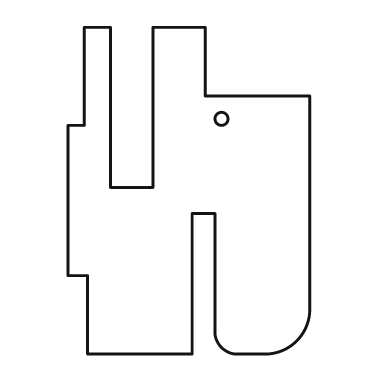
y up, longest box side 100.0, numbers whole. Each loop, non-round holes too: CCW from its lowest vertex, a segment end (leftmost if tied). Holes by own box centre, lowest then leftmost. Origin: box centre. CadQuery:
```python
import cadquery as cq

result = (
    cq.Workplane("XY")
    .moveTo(-31.0, -50.0)
    .lineTo(1.0, -50.0)
    .lineTo(1.0, -7.0)
    .lineTo(8.0, -7.0)
    .lineTo(8.0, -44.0)
    .threePointArc((10.0, -48.0), (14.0, -50.0))
    .lineTo(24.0, -50.0)
    .threePointArc((33.0, -46.0), (37.0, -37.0))
    .lineTo(37.0, 29.0)
    .lineTo(5.0, 29.0)
    .lineTo(5.0, 50.0)
    .lineTo(-11.0, 50.0)
    .lineTo(-11.0, 1.0)
    .lineTo(-24.0, 1.0)
    .lineTo(-24.0, 50.0)
    .lineTo(-32.0, 50.0)
    .lineTo(-32.0, 20.0)
    .lineTo(-37.0, 20.0)
    .lineTo(-37.0, -26.0)
    .lineTo(-31.0, -26.0)
    .close()
    .moveTo(10.0, 22.0)
    .circle(2.0)
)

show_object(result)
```